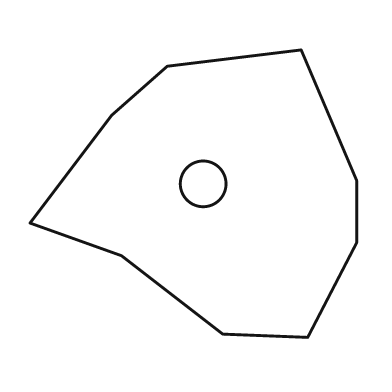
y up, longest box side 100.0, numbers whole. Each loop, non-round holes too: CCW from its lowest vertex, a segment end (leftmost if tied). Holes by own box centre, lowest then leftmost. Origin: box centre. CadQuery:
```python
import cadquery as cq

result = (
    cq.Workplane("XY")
    .moveTo(35.0, -44.0)
    .lineTo(50.0, -15.0)
    .lineTo(50.0, 4.0)
    .lineTo(33.0, 44.0)
    .lineTo(-8.0, 39.0)
    .lineTo(-25.0, 24.0)
    .lineTo(-50.0, -9.0)
    .lineTo(-22.0, -19.0)
    .lineTo(9.0, -43.0)
    .close()
    .moveTo(3.0, 3.0)
    .circle(7.0)
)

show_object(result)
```